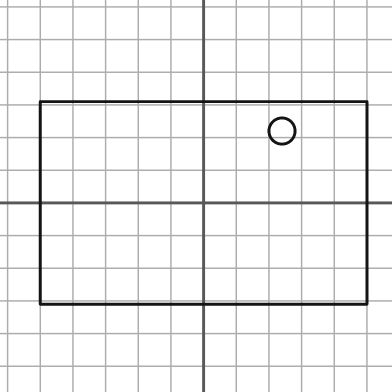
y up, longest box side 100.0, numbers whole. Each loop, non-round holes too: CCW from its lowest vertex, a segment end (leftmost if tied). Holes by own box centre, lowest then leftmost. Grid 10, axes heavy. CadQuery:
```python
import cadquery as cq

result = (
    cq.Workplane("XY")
    .moveTo(-50.0, -31.0)
    .lineTo(50.0, -31.0)
    .lineTo(50.0, 31.0)
    .lineTo(-50.0, 31.0)
    .close()
    .moveTo(24.0, 22.0)
    .circle(4.0)
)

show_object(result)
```